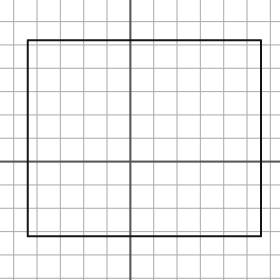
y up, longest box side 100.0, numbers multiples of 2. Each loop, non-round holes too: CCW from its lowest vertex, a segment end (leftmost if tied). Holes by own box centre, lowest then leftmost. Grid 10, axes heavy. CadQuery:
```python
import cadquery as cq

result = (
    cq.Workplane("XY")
    .moveTo(-44.0, -32.0)
    .lineTo(56.0, -32.0)
    .lineTo(56.0, 52.0)
    .lineTo(-44.0, 52.0)
    .close()
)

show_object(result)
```